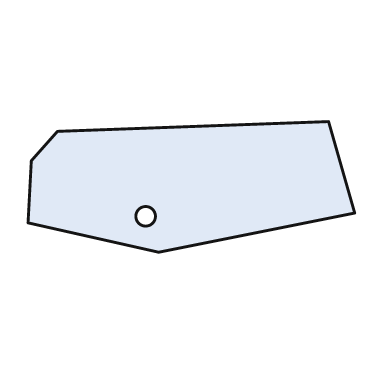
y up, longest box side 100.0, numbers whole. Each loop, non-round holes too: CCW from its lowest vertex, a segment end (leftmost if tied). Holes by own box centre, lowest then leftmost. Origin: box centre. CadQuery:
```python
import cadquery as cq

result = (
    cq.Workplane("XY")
    .moveTo(-10.0, -20.0)
    .lineTo(50.0, -8.0)
    .lineTo(42.0, 20.0)
    .lineTo(-41.0, 17.0)
    .lineTo(-49.0, 8.0)
    .lineTo(-50.0, -11.0)
    .close()
    .moveTo(-14.0, -9.0)
    .circle(3.0)
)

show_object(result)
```